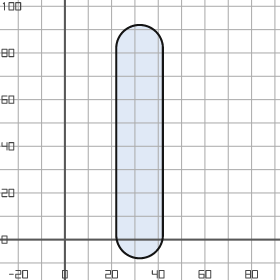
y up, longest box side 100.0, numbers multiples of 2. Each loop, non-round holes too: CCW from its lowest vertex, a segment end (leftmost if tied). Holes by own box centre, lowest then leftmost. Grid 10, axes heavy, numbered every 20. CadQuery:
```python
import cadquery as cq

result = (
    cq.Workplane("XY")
    .moveTo(22.0, 2.0)
    .threePointArc((32.0, -8.0), (42.0, 2.0))
    .lineTo(42.0, 82.0)
    .threePointArc((32.0, 92.0), (22.0, 82.0))
    .close()
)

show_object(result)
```